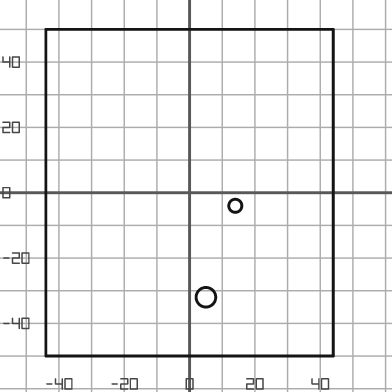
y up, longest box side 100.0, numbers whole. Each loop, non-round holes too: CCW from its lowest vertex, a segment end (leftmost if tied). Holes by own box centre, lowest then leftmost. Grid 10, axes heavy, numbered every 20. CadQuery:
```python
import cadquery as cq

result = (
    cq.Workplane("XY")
    .moveTo(-44.0, -50.0)
    .lineTo(44.0, -50.0)
    .lineTo(44.0, 50.0)
    .lineTo(-44.0, 50.0)
    .close()
    .moveTo(5.0, -32.0)
    .circle(3.0)
    .moveTo(14.0, -4.0)
    .circle(2.0)
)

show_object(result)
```